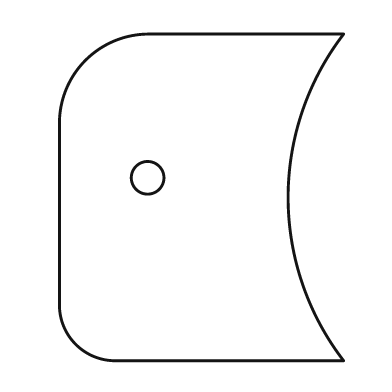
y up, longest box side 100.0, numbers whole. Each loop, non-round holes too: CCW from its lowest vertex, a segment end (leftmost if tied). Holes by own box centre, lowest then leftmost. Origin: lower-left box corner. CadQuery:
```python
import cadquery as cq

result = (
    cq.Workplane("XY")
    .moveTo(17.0, 0.0)
    .lineTo(87.0, 0.0)
    .threePointArc((70.0, 50.0), (87.0, 100.0))
    .lineTo(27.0, 100.0)
    .threePointArc((8.0, 92.0), (0.0, 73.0))
    .lineTo(0.0, 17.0)
    .threePointArc((5.0, 5.0), (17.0, 0.0))
    .close()
    .moveTo(27.0, 56.0)
    .circle(5.0)
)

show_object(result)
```